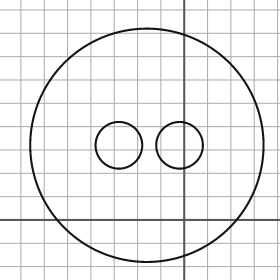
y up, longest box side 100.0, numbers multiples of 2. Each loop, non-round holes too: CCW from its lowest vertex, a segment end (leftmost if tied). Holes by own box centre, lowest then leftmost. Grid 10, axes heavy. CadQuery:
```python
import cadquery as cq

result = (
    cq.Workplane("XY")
    .moveTo(-16.0, 32.0)
    .circle(50.0)
    .moveTo(-28.0, 32.0)
    .circle(10.0)
    .moveTo(-2.0, 32.0)
    .circle(10.0)
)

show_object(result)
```